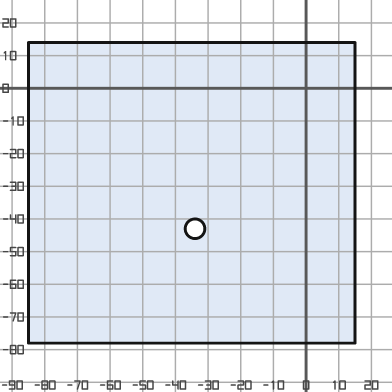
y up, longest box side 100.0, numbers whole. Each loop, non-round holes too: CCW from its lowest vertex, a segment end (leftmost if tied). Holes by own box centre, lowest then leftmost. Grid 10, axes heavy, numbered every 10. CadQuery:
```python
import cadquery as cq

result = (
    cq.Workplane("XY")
    .moveTo(-85.0, -78.0)
    .lineTo(15.0, -78.0)
    .lineTo(15.0, 14.0)
    .lineTo(-85.0, 14.0)
    .close()
    .moveTo(-34.0, -43.0)
    .circle(3.0)
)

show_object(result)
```